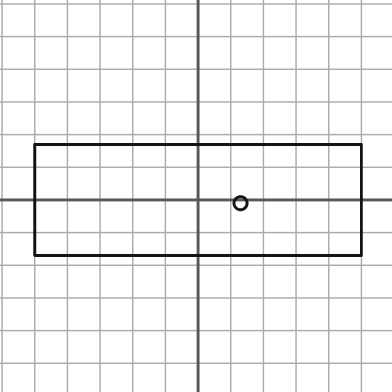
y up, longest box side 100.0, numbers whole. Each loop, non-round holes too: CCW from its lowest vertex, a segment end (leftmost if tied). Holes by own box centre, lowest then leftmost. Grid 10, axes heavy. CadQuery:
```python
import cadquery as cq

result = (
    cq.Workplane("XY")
    .moveTo(-50.0, -17.0)
    .lineTo(50.0, -17.0)
    .lineTo(50.0, 17.0)
    .lineTo(-50.0, 17.0)
    .close()
    .moveTo(13.0, -1.0)
    .circle(2.0)
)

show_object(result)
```